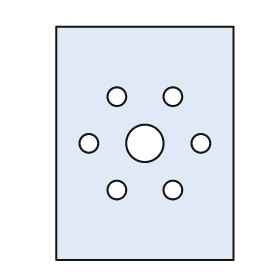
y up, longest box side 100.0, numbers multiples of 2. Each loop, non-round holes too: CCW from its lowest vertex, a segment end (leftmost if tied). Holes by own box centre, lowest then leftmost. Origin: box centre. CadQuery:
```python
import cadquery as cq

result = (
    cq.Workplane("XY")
    .moveTo(-38.0, -50.0)
    .lineTo(38.0, -50.0)
    .lineTo(38.0, 50.0)
    .lineTo(-38.0, 50.0)
    .close()
    .moveTo(-12.0, -20.0)
    .circle(4.0)
    .moveTo(12.0, -20.0)
    .circle(4.0)
    .moveTo(-24.0, 0.0)
    .circle(4.0)
    .moveTo(0.0, 0.0)
    .circle(8.0)
    .moveTo(24.0, 0.0)
    .circle(4.0)
    .moveTo(-12.0, 20.0)
    .circle(4.0)
    .moveTo(12.0, 20.0)
    .circle(4.0)
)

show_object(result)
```